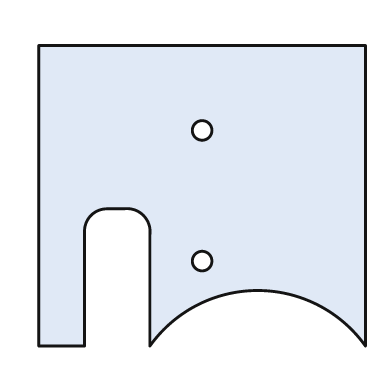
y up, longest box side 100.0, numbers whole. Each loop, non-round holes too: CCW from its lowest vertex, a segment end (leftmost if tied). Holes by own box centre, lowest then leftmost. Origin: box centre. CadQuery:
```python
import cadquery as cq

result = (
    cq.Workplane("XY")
    .moveTo(-50.0, -46.0)
    .lineTo(-36.0, -46.0)
    .lineTo(-36.0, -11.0)
    .threePointArc((-34.0, -6.0), (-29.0, -4.0))
    .lineTo(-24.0, -4.0)
    .threePointArc((-18.0, -6.0), (-16.0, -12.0))
    .lineTo(-16.0, -46.0)
    .threePointArc((17.0, -29.0), (50.0, -46.0))
    .lineTo(50.0, 46.0)
    .lineTo(-50.0, 46.0)
    .close()
    .moveTo(0.0, -20.0)
    .circle(3.0)
    .moveTo(0.0, 20.0)
    .circle(3.0)
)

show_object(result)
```